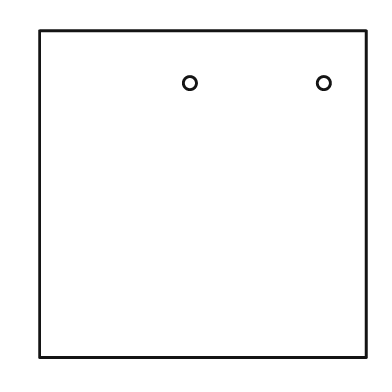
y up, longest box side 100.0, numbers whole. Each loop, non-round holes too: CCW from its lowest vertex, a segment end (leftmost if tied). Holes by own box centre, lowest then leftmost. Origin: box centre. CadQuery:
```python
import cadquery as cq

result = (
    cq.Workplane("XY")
    .moveTo(-50.0, -50.0)
    .lineTo(50.0, -50.0)
    .lineTo(50.0, 50.0)
    .lineTo(-50.0, 50.0)
    .close()
    .moveTo(-4.0, 34.0)
    .circle(2.0)
    .moveTo(37.0, 34.0)
    .circle(2.0)
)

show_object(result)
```